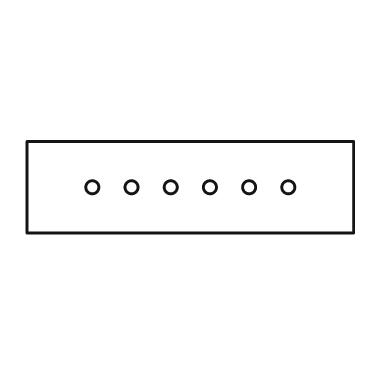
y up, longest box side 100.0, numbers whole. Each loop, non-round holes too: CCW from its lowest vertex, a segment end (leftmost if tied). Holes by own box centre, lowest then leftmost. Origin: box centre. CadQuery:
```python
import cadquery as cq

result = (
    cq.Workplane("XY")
    .moveTo(-50.0, -14.0)
    .lineTo(50.0, -14.0)
    .lineTo(50.0, 14.0)
    .lineTo(-50.0, 14.0)
    .close()
    .moveTo(-30.0, 0.0)
    .circle(2.0)
    .moveTo(-18.0, 0.0)
    .circle(2.0)
    .moveTo(-6.0, 0.0)
    .circle(2.0)
    .moveTo(6.0, 0.0)
    .circle(2.0)
    .moveTo(18.0, 0.0)
    .circle(2.0)
    .moveTo(30.0, 0.0)
    .circle(2.0)
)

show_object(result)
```